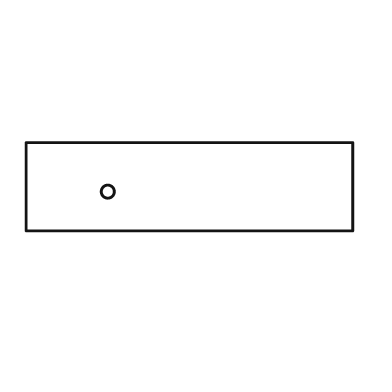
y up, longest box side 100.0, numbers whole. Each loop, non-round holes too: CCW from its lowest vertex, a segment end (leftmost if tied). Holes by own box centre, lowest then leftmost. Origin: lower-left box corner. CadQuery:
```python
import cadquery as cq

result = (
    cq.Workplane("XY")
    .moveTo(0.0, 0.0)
    .lineTo(100.0, 0.0)
    .lineTo(100.0, 27.0)
    .lineTo(0.0, 27.0)
    .close()
    .moveTo(25.0, 12.0)
    .circle(2.0)
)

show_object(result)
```